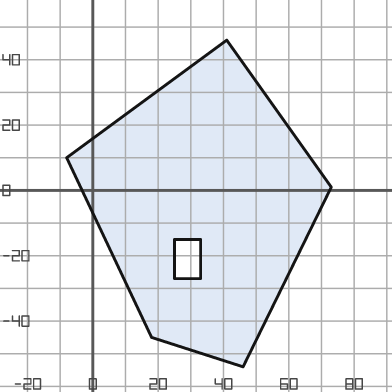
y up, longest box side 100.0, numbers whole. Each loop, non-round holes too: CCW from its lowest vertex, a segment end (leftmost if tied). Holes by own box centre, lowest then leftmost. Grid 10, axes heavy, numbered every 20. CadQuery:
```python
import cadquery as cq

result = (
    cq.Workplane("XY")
    .moveTo(46.0, -54.0)
    .lineTo(73.0, 1.0)
    .lineTo(41.0, 46.0)
    .lineTo(-8.0, 10.0)
    .lineTo(18.0, -45.0)
    .close()
    .moveTo(25.0, -27.0)
    .lineTo(33.0, -27.0)
    .lineTo(33.0, -15.0)
    .lineTo(25.0, -15.0)
    .close()
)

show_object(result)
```